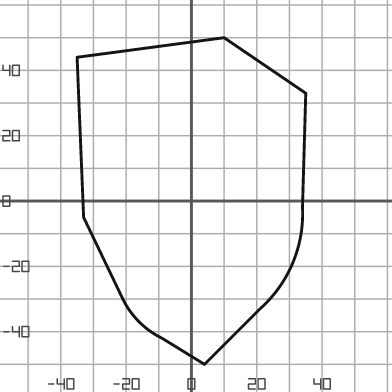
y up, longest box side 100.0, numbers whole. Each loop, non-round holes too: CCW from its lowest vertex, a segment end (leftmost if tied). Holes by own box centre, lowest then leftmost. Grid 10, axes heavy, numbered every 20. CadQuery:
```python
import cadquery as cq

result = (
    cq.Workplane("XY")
    .moveTo(4.0, -50.0)
    .lineTo(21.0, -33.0)
    .threePointArc((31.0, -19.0), (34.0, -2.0))
    .lineTo(35.0, 33.0)
    .lineTo(10.0, 50.0)
    .lineTo(-35.0, 44.0)
    .lineTo(-33.0, -5.0)
    .lineTo(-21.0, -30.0)
    .threePointArc((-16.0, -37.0), (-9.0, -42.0))
    .close()
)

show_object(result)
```